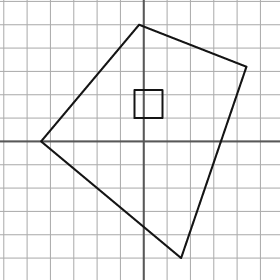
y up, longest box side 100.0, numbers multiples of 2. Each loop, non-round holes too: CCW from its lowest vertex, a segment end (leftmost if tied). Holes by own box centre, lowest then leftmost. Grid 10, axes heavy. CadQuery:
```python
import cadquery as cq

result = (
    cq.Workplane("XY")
    .moveTo(16.0, -50.0)
    .lineTo(44.0, 32.0)
    .lineTo(-2.0, 50.0)
    .lineTo(-44.0, 0.0)
    .close()
    .moveTo(-4.0, 10.0)
    .lineTo(8.0, 10.0)
    .lineTo(8.0, 22.0)
    .lineTo(-4.0, 22.0)
    .close()
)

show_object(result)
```